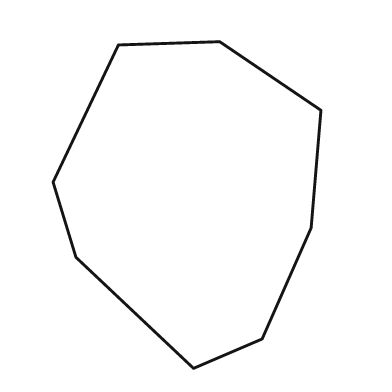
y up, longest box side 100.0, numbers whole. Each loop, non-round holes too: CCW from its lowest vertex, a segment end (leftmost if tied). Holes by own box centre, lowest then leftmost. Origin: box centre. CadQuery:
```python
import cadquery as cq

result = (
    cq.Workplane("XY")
    .moveTo(2.0, -50.0)
    .lineTo(23.0, -41.0)
    .lineTo(38.0, -7.0)
    .lineTo(41.0, 29.0)
    .lineTo(10.0, 50.0)
    .lineTo(-21.0, 49.0)
    .lineTo(-41.0, 7.0)
    .lineTo(-34.0, -16.0)
    .close()
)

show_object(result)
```